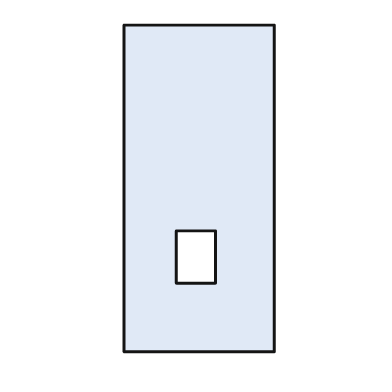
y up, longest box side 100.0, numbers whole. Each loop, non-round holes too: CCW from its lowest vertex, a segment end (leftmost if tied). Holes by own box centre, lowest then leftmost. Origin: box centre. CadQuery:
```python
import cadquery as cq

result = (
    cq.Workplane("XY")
    .moveTo(-23.0, -50.0)
    .lineTo(23.0, -50.0)
    .lineTo(23.0, 50.0)
    .lineTo(-23.0, 50.0)
    .close()
    .moveTo(-7.0, -29.0)
    .lineTo(5.0, -29.0)
    .lineTo(5.0, -13.0)
    .lineTo(-7.0, -13.0)
    .close()
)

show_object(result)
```